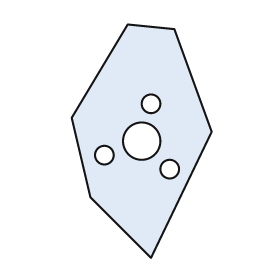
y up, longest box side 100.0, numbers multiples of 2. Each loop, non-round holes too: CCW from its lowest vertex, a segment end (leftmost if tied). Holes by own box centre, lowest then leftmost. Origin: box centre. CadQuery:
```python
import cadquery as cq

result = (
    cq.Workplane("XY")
    .moveTo(4.0, -50.0)
    .lineTo(30.0, 4.0)
    .lineTo(14.0, 48.0)
    .lineTo(-6.0, 50.0)
    .lineTo(-30.0, 10.0)
    .lineTo(-22.0, -24.0)
    .close()
    .moveTo(12.0, -12.0)
    .circle(4.0)
    .moveTo(-16.0, -6.0)
    .circle(4.0)
    .moveTo(0.0, 0.0)
    .circle(8.0)
    .moveTo(4.0, 16.0)
    .circle(4.0)
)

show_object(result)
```